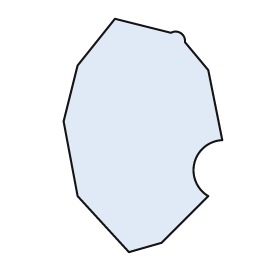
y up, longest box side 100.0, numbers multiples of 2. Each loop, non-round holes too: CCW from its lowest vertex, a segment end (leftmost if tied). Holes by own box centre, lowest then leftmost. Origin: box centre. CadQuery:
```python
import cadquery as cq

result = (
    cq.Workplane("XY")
    .moveTo(-6.0, -50.0)
    .lineTo(8.0, -46.0)
    .lineTo(28.0, -26.0)
    .threePointArc((22.0, -12.0), (34.0, -2.0))
    .lineTo(28.0, 28.0)
    .lineTo(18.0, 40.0)
    .threePointArc((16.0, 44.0), (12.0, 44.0))
    .lineTo(-12.0, 50.0)
    .lineTo(-28.0, 30.0)
    .lineTo(-34.0, 6.0)
    .lineTo(-28.0, -26.0)
    .close()
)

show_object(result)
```